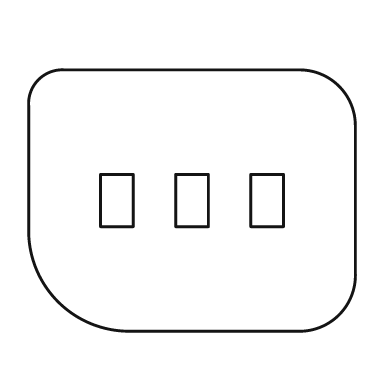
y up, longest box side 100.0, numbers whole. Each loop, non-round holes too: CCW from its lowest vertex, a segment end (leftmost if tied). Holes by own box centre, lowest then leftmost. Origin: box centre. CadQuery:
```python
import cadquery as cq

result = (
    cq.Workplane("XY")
    .moveTo(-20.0, -40.0)
    .lineTo(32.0, -40.0)
    .threePointArc((45.0, -35.0), (50.0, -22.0))
    .lineTo(50.0, 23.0)
    .threePointArc((45.0, 35.0), (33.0, 40.0))
    .lineTo(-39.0, 40.0)
    .threePointArc((-47.0, 37.0), (-50.0, 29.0))
    .lineTo(-50.0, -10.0)
    .threePointArc((-41.0, -31.0), (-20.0, -40.0))
    .close()
    .moveTo(-28.0, -8.0)
    .lineTo(-18.0, -8.0)
    .lineTo(-18.0, 8.0)
    .lineTo(-28.0, 8.0)
    .close()
    .moveTo(-5.0, -8.0)
    .lineTo(5.0, -8.0)
    .lineTo(5.0, 8.0)
    .lineTo(-5.0, 8.0)
    .close()
    .moveTo(18.0, -8.0)
    .lineTo(28.0, -8.0)
    .lineTo(28.0, 8.0)
    .lineTo(18.0, 8.0)
    .close()
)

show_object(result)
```